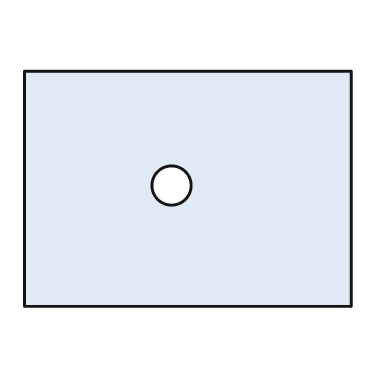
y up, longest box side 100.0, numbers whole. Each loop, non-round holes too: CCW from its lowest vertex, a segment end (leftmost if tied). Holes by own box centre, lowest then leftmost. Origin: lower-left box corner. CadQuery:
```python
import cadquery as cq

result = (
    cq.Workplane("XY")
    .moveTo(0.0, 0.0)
    .lineTo(100.0, 0.0)
    .lineTo(100.0, 72.0)
    .lineTo(0.0, 72.0)
    .close()
    .moveTo(45.0, 37.0)
    .circle(6.0)
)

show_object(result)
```